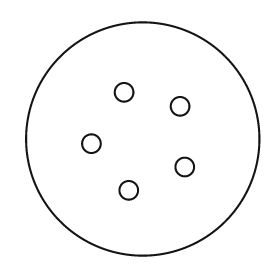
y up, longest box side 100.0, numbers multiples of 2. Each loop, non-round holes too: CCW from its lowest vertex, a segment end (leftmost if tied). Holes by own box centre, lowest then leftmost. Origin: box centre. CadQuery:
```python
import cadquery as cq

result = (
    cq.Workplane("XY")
    .moveTo(0.0, 0.0)
    .circle(50.0)
    .moveTo(-6.0, -22.0)
    .circle(4.0)
    .moveTo(18.0, -12.0)
    .circle(4.0)
    .moveTo(-22.0, -2.0)
    .circle(4.0)
    .moveTo(16.0, 14.0)
    .circle(4.0)
    .moveTo(-8.0, 20.0)
    .circle(4.0)
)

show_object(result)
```